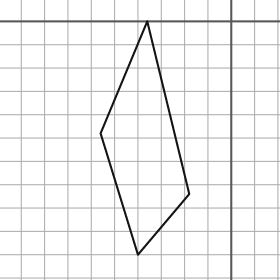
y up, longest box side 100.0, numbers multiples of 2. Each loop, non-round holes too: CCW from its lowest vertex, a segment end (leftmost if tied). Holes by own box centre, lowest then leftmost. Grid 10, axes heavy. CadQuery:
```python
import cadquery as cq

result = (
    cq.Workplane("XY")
    .moveTo(-40.0, -100.0)
    .lineTo(-18.0, -74.0)
    .lineTo(-36.0, 0.0)
    .lineTo(-56.0, -48.0)
    .close()
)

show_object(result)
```